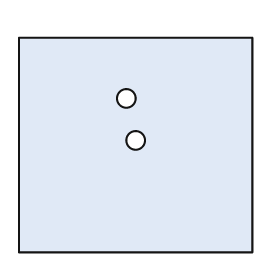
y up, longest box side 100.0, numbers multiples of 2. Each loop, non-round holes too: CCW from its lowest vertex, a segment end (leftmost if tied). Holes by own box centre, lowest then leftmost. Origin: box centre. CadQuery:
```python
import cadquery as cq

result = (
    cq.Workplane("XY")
    .moveTo(-50.0, -46.0)
    .lineTo(50.0, -46.0)
    .lineTo(50.0, 46.0)
    .lineTo(-50.0, 46.0)
    .close()
    .moveTo(0.0, 2.0)
    .circle(4.0)
    .moveTo(-4.0, 20.0)
    .circle(4.0)
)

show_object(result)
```